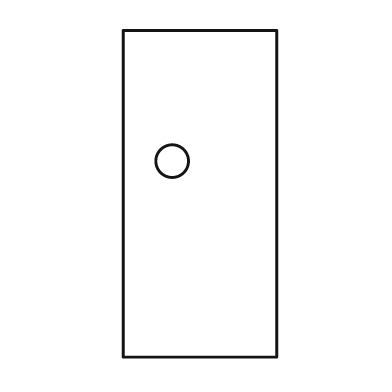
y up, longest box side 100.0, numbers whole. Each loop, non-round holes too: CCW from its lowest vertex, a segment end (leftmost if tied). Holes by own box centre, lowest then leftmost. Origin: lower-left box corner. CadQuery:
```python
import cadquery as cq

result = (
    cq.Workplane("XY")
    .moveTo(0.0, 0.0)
    .lineTo(47.0, 0.0)
    .lineTo(47.0, 100.0)
    .lineTo(0.0, 100.0)
    .close()
    .moveTo(15.0, 60.0)
    .circle(5.0)
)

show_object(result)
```